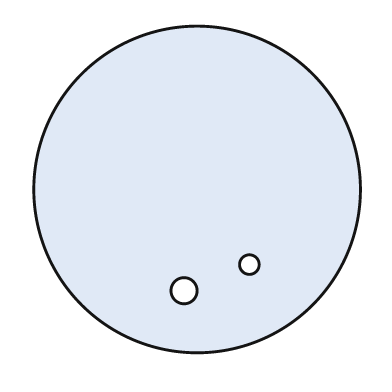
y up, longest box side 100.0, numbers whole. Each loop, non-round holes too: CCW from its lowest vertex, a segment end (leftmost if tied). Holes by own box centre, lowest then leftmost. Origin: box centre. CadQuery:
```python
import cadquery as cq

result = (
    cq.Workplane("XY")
    .moveTo(0.0, 0.0)
    .circle(50.0)
    .moveTo(-4.0, -31.0)
    .circle(4.0)
    .moveTo(16.0, -23.0)
    .circle(3.0)
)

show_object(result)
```